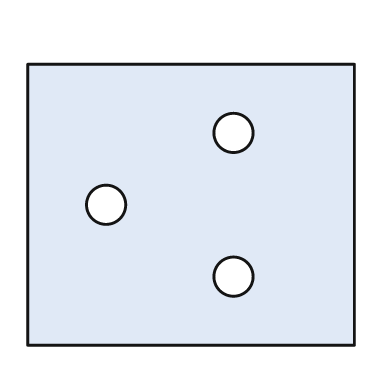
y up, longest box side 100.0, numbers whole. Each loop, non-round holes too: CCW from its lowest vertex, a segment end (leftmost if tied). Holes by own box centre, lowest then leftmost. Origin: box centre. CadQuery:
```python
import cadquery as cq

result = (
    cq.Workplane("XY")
    .moveTo(-50.0, -43.0)
    .lineTo(50.0, -43.0)
    .lineTo(50.0, 43.0)
    .lineTo(-50.0, 43.0)
    .close()
    .moveTo(13.0, -22.0)
    .circle(6.0)
    .moveTo(-26.0, 0.0)
    .circle(6.0)
    .moveTo(13.0, 22.0)
    .circle(6.0)
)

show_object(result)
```